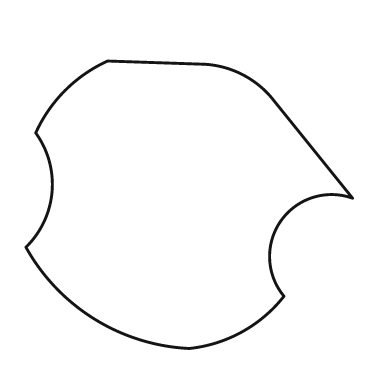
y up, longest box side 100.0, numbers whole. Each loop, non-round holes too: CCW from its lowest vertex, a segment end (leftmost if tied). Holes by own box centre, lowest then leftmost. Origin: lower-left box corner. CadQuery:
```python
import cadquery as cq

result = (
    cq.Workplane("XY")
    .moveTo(50.0, 0.0)
    .threePointArc((66.0, 5.0), (79.0, 16.0))
    .threePointArc((78.0, 39.0), (100.0, 46.0))
    .lineTo(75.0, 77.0)
    .threePointArc((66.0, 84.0), (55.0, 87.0))
    .lineTo(25.0, 88.0)
    .threePointArc((12.0, 79.0), (3.0, 66.0))
    .threePointArc((8.0, 48.0), (0.0, 31.0))
    .threePointArc((21.0, 9.0), (50.0, 0.0))
    .close()
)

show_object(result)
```